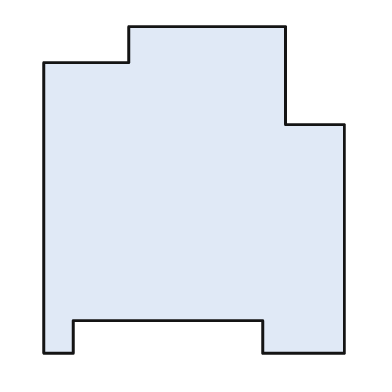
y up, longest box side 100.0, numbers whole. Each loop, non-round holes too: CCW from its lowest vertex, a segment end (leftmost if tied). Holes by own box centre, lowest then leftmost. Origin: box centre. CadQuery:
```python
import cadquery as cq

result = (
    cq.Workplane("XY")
    .moveTo(-46.0, -50.0)
    .lineTo(-37.0, -50.0)
    .lineTo(-37.0, -40.0)
    .lineTo(21.0, -40.0)
    .lineTo(21.0, -50.0)
    .lineTo(46.0, -50.0)
    .lineTo(46.0, 20.0)
    .lineTo(28.0, 20.0)
    .lineTo(28.0, 50.0)
    .lineTo(-20.0, 50.0)
    .lineTo(-20.0, 39.0)
    .lineTo(-46.0, 39.0)
    .close()
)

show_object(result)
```